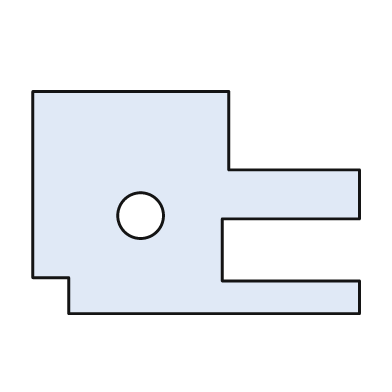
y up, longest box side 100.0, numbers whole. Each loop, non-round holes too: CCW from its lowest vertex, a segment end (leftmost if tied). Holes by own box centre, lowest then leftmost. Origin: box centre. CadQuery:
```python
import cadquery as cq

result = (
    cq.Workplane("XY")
    .moveTo(-39.0, -34.0)
    .lineTo(50.0, -34.0)
    .lineTo(50.0, -24.0)
    .lineTo(8.0, -24.0)
    .lineTo(8.0, -5.0)
    .lineTo(50.0, -5.0)
    .lineTo(50.0, 10.0)
    .lineTo(10.0, 10.0)
    .lineTo(10.0, 34.0)
    .lineTo(-50.0, 34.0)
    .lineTo(-50.0, -23.0)
    .lineTo(-39.0, -23.0)
    .close()
    .moveTo(-17.0, -4.0)
    .circle(7.0)
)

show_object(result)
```